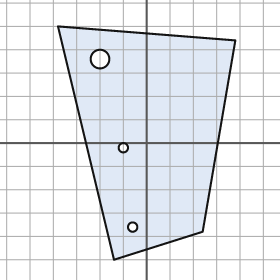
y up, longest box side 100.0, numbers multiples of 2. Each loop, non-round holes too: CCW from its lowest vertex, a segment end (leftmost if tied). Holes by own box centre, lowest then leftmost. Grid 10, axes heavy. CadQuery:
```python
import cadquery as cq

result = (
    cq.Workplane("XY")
    .moveTo(-14.0, -50.0)
    .lineTo(24.0, -38.0)
    .lineTo(38.0, 44.0)
    .lineTo(-38.0, 50.0)
    .close()
    .moveTo(-6.0, -36.0)
    .circle(2.0)
    .moveTo(-10.0, -2.0)
    .circle(2.0)
    .moveTo(-20.0, 36.0)
    .circle(4.0)
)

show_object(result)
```